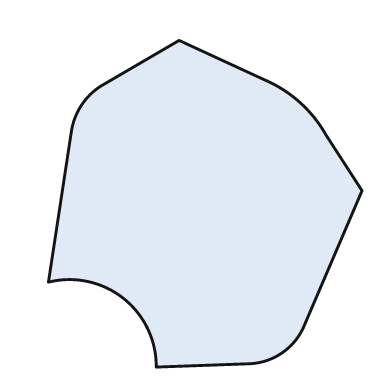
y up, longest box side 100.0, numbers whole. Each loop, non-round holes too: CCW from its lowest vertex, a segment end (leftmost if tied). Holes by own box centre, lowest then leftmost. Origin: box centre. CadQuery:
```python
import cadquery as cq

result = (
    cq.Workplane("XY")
    .moveTo(-15.0, -50.0)
    .lineTo(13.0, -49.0)
    .threePointArc((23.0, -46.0), (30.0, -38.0))
    .lineTo(48.0, 4.0)
    .lineTo(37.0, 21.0)
    .threePointArc((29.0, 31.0), (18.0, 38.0))
    .lineTo(-8.0, 50.0)
    .lineTo(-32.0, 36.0)
    .threePointArc((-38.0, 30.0), (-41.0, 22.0))
    .lineTo(-48.0, -24.0)
    .threePointArc((-25.0, -29.0), (-15.0, -50.0))
    .close()
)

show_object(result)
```